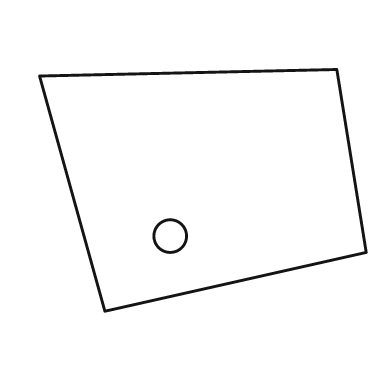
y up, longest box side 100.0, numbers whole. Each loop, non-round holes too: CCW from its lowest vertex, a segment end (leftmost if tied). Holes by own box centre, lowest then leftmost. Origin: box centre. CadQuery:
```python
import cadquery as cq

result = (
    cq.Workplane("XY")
    .moveTo(-30.0, -37.0)
    .lineTo(50.0, -19.0)
    .lineTo(41.0, 37.0)
    .lineTo(-50.0, 35.0)
    .close()
    .moveTo(-10.0, -14.0)
    .circle(5.0)
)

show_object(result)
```